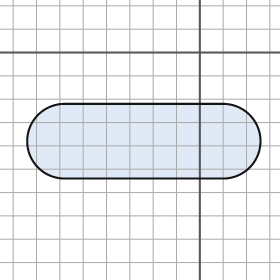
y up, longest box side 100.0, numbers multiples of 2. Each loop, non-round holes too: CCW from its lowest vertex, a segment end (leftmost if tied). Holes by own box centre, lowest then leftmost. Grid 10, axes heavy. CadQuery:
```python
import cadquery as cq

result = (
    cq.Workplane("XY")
    .moveTo(-58.0, -54.0)
    .lineTo(10.0, -54.0)
    .threePointArc((26.0, -38.0), (10.0, -22.0))
    .lineTo(-58.0, -22.0)
    .threePointArc((-74.0, -38.0), (-58.0, -54.0))
    .close()
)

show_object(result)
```